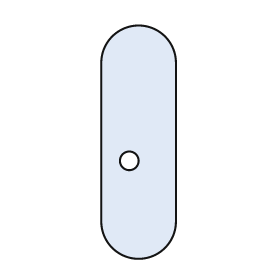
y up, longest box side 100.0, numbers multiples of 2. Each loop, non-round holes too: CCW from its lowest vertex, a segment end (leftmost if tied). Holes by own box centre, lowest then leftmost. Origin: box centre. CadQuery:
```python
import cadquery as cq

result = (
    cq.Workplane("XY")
    .moveTo(-16.0, -34.0)
    .threePointArc((0.0, -50.0), (16.0, -34.0))
    .lineTo(16.0, 34.0)
    .threePointArc((0.0, 50.0), (-16.0, 34.0))
    .close()
    .moveTo(-4.0, -8.0)
    .circle(4.0)
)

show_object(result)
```